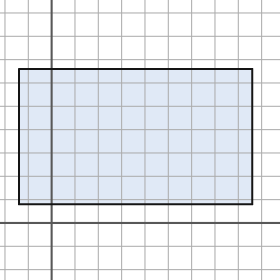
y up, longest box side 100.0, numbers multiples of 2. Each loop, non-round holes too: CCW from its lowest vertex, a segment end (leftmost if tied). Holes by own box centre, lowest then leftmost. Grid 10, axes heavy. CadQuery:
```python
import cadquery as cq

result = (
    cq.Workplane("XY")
    .moveTo(-14.0, 8.0)
    .lineTo(86.0, 8.0)
    .lineTo(86.0, 66.0)
    .lineTo(-14.0, 66.0)
    .close()
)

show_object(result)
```